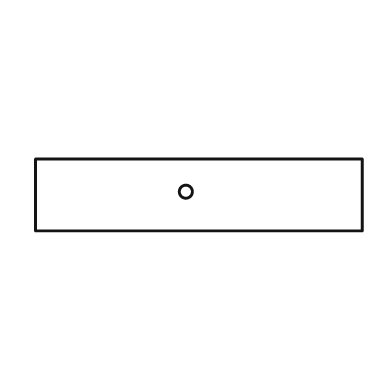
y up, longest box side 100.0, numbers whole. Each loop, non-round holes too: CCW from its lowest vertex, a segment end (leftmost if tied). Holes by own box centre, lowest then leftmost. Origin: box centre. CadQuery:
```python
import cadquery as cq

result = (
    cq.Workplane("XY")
    .moveTo(-50.0, -11.0)
    .lineTo(50.0, -11.0)
    .lineTo(50.0, 11.0)
    .lineTo(-50.0, 11.0)
    .close()
    .moveTo(-4.0, 1.0)
    .circle(2.0)
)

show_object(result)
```